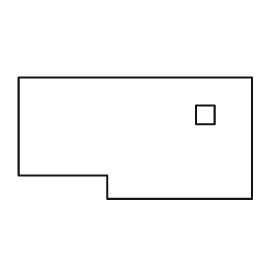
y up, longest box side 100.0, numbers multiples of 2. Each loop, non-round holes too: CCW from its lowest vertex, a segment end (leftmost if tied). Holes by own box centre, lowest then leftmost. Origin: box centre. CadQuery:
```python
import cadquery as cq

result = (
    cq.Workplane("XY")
    .moveTo(-12.0, -26.0)
    .lineTo(50.0, -26.0)
    .lineTo(50.0, 26.0)
    .lineTo(-50.0, 26.0)
    .lineTo(-50.0, -16.0)
    .lineTo(-12.0, -16.0)
    .close()
    .moveTo(26.0, 6.0)
    .lineTo(34.0, 6.0)
    .lineTo(34.0, 14.0)
    .lineTo(26.0, 14.0)
    .close()
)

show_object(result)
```